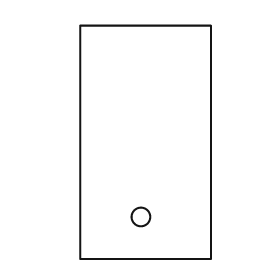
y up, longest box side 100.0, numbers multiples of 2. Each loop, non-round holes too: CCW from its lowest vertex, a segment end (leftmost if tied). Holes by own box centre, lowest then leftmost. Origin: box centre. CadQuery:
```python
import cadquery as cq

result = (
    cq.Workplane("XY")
    .moveTo(-28.0, -50.0)
    .lineTo(28.0, -50.0)
    .lineTo(28.0, 50.0)
    .lineTo(-28.0, 50.0)
    .close()
    .moveTo(-2.0, -32.0)
    .circle(4.0)
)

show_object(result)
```